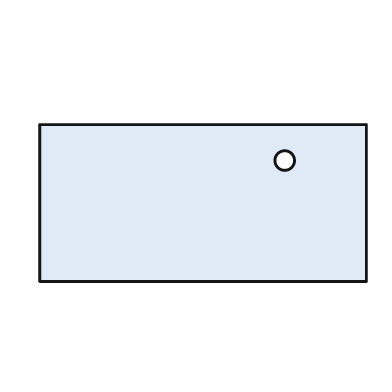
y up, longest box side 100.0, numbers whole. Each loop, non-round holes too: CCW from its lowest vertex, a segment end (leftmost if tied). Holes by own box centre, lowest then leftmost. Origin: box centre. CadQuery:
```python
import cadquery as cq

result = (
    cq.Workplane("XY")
    .moveTo(-50.0, -24.0)
    .lineTo(50.0, -24.0)
    .lineTo(50.0, 24.0)
    .lineTo(-50.0, 24.0)
    .close()
    .moveTo(25.0, 13.0)
    .circle(3.0)
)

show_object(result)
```